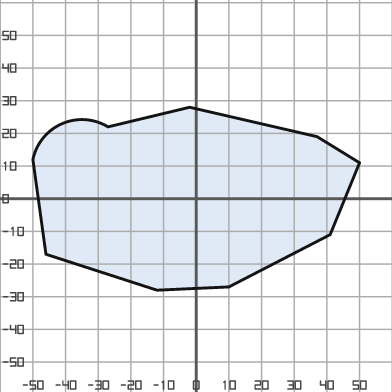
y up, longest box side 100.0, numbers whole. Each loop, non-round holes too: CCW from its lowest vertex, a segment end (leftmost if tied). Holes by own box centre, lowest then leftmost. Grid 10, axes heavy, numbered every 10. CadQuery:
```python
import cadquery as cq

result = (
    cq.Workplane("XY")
    .moveTo(-12.0, -28.0)
    .lineTo(10.0, -27.0)
    .lineTo(41.0, -11.0)
    .lineTo(50.0, 11.0)
    .lineTo(37.0, 19.0)
    .lineTo(-2.0, 28.0)
    .lineTo(-27.0, 22.0)
    .threePointArc((-41.0, 23.0), (-50.0, 12.0))
    .lineTo(-46.0, -17.0)
    .close()
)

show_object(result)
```